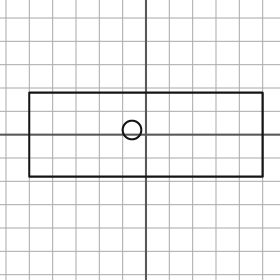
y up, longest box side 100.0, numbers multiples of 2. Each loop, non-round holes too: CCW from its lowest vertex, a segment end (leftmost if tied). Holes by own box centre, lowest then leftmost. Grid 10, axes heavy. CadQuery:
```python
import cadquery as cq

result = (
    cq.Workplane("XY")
    .moveTo(-50.0, -18.0)
    .lineTo(50.0, -18.0)
    .lineTo(50.0, 18.0)
    .lineTo(-50.0, 18.0)
    .close()
    .moveTo(-6.0, 2.0)
    .circle(4.0)
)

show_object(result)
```